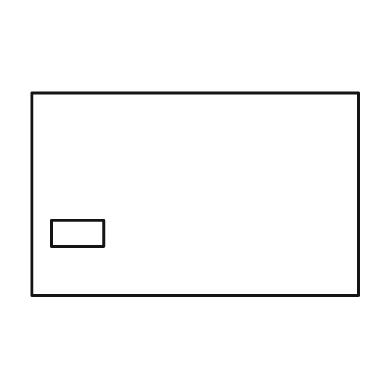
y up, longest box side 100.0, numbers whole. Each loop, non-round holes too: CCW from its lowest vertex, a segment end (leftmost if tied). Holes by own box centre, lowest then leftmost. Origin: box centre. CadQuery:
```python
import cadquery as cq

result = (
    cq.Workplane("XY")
    .moveTo(-50.0, -31.0)
    .lineTo(50.0, -31.0)
    .lineTo(50.0, 31.0)
    .lineTo(-50.0, 31.0)
    .close()
    .moveTo(-44.0, -16.0)
    .lineTo(-28.0, -16.0)
    .lineTo(-28.0, -8.0)
    .lineTo(-44.0, -8.0)
    .close()
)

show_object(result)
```